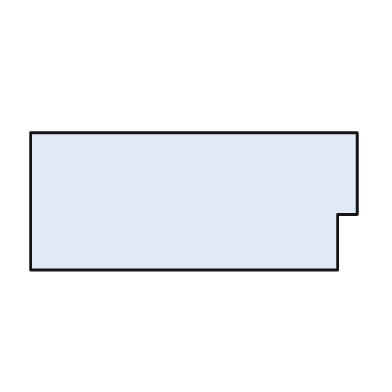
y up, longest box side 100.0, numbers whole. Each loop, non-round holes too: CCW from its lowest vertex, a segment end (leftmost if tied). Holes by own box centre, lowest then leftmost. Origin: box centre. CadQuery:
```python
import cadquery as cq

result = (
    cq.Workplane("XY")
    .moveTo(-50.0, -21.0)
    .lineTo(44.0, -21.0)
    .lineTo(44.0, -4.0)
    .lineTo(50.0, -4.0)
    .lineTo(50.0, 21.0)
    .lineTo(-50.0, 21.0)
    .close()
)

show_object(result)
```